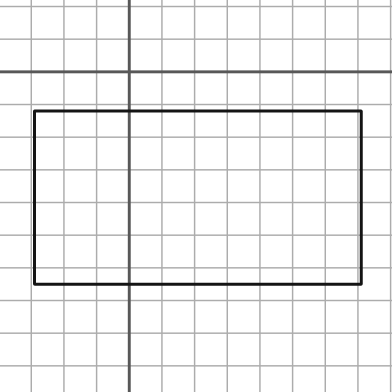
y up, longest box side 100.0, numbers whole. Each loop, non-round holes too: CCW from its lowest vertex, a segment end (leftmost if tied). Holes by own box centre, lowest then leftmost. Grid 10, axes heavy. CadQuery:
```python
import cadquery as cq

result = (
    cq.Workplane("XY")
    .moveTo(-29.0, -65.0)
    .lineTo(71.0, -65.0)
    .lineTo(71.0, -12.0)
    .lineTo(-29.0, -12.0)
    .close()
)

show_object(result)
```